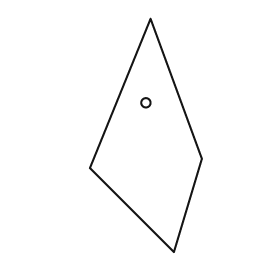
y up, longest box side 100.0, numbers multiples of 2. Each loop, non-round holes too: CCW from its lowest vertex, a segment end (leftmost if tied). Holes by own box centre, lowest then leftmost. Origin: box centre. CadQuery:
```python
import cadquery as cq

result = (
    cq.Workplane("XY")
    .moveTo(12.0, -50.0)
    .lineTo(24.0, -10.0)
    .lineTo(2.0, 50.0)
    .lineTo(-24.0, -14.0)
    .close()
    .moveTo(0.0, 14.0)
    .circle(2.0)
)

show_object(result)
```